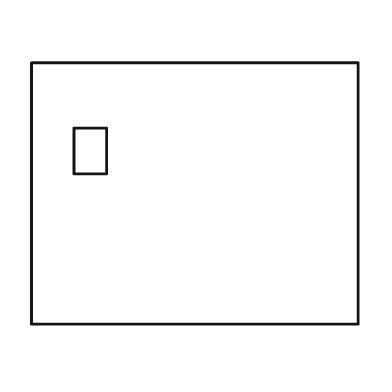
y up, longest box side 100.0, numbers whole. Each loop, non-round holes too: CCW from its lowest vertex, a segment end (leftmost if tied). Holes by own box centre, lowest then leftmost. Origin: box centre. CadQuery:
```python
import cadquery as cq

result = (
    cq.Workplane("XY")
    .moveTo(-50.0, -40.0)
    .lineTo(50.0, -40.0)
    .lineTo(50.0, 40.0)
    .lineTo(-50.0, 40.0)
    .close()
    .moveTo(-37.0, 6.0)
    .lineTo(-27.0, 6.0)
    .lineTo(-27.0, 20.0)
    .lineTo(-37.0, 20.0)
    .close()
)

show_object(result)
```